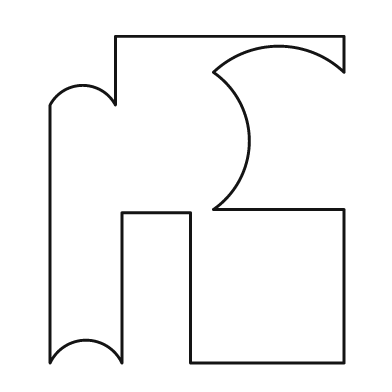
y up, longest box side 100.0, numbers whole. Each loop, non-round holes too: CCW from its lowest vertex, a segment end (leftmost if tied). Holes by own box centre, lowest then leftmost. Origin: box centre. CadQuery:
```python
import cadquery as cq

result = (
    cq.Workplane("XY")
    .moveTo(-45.0, -50.0)
    .threePointArc((-34.0, -43.0), (-23.0, -50.0))
    .lineTo(-23.0, -4.0)
    .lineTo(-2.0, -4.0)
    .lineTo(-2.0, -50.0)
    .lineTo(45.0, -50.0)
    .lineTo(45.0, -3.0)
    .lineTo(5.0, -3.0)
    .threePointArc((16.0, 18.0), (5.0, 39.0))
    .threePointArc((25.0, 47.0), (45.0, 39.0))
    .lineTo(45.0, 50.0)
    .lineTo(-25.0, 50.0)
    .lineTo(-25.0, 29.0)
    .threePointArc((-35.0, 35.0), (-45.0, 29.0))
    .close()
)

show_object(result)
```